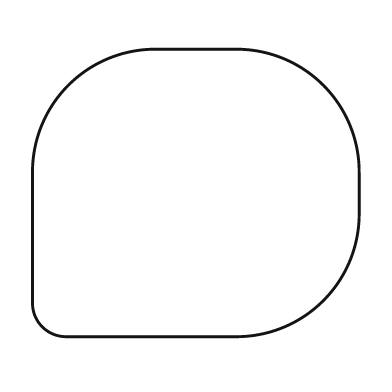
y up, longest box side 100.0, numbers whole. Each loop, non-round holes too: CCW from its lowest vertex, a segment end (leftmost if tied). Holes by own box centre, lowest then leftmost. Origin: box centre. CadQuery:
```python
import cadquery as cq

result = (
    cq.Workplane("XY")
    .moveTo(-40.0, -44.0)
    .lineTo(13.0, -44.0)
    .threePointArc((39.0, -33.0), (50.0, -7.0))
    .lineTo(50.0, 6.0)
    .threePointArc((39.0, 33.0), (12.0, 44.0))
    .lineTo(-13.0, 44.0)
    .threePointArc((-39.0, 33.0), (-50.0, 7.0))
    .lineTo(-50.0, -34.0)
    .threePointArc((-47.0, -41.0), (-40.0, -44.0))
    .close()
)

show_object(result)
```